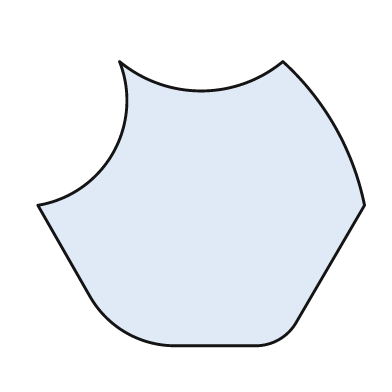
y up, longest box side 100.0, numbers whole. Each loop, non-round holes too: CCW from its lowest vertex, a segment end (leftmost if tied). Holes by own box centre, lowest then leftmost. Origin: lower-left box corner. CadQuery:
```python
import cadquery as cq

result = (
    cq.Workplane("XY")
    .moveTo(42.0, 0.0)
    .lineTo(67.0, 0.0)
    .threePointArc((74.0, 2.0), (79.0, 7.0))
    .lineTo(100.0, 43.0)
    .threePointArc((91.0, 67.0), (75.0, 87.0))
    .threePointArc((50.0, 78.0), (25.0, 87.0))
    .threePointArc((23.0, 59.0), (0.0, 43.0))
    .lineTo(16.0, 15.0)
    .threePointArc((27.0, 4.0), (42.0, 0.0))
    .close()
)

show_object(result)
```